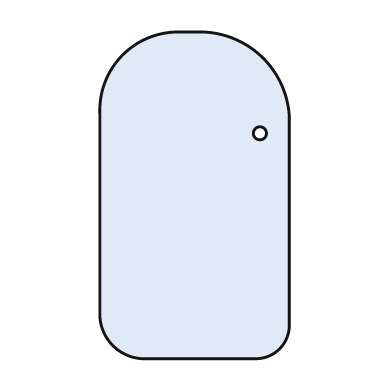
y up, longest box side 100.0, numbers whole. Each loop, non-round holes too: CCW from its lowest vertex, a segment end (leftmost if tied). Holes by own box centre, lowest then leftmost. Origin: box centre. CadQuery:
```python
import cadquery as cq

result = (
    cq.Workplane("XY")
    .moveTo(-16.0, -50.0)
    .lineTo(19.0, -50.0)
    .threePointArc((26.0, -47.0), (29.0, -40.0))
    .lineTo(29.0, 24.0)
    .threePointArc((21.0, 42.0), (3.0, 50.0))
    .lineTo(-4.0, 50.0)
    .threePointArc((-22.0, 43.0), (-29.0, 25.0))
    .lineTo(-29.0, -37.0)
    .threePointArc((-25.0, -46.0), (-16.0, -50.0))
    .close()
    .moveTo(20.0, 19.0)
    .circle(2.0)
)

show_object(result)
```